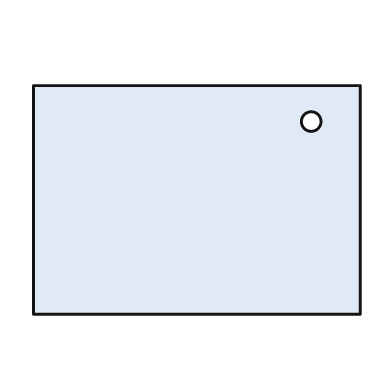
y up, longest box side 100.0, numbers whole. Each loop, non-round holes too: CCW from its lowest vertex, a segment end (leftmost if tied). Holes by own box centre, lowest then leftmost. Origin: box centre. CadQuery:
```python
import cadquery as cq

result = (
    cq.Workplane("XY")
    .moveTo(-50.0, -35.0)
    .lineTo(50.0, -35.0)
    .lineTo(50.0, 35.0)
    .lineTo(-50.0, 35.0)
    .close()
    .moveTo(35.0, 24.0)
    .circle(3.0)
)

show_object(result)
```